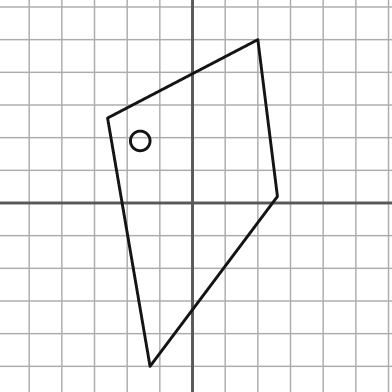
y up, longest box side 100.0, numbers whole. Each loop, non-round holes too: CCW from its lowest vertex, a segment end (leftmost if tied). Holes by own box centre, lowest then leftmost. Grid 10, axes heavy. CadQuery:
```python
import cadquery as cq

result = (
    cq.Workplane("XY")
    .moveTo(-13.0, -50.0)
    .lineTo(26.0, 2.0)
    .lineTo(20.0, 50.0)
    .lineTo(-26.0, 26.0)
    .close()
    .moveTo(-16.0, 19.0)
    .circle(3.0)
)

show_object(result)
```